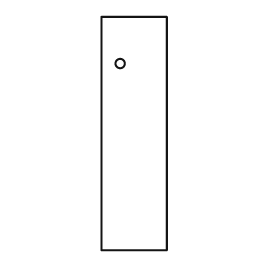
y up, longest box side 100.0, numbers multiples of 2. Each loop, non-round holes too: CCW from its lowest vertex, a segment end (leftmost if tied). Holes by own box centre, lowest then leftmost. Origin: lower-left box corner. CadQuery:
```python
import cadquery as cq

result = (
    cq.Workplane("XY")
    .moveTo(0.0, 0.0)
    .lineTo(28.0, 0.0)
    .lineTo(28.0, 100.0)
    .lineTo(0.0, 100.0)
    .close()
    .moveTo(8.0, 80.0)
    .circle(2.0)
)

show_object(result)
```